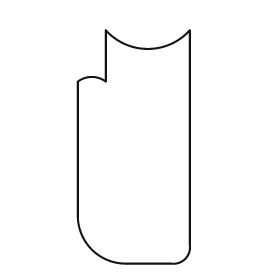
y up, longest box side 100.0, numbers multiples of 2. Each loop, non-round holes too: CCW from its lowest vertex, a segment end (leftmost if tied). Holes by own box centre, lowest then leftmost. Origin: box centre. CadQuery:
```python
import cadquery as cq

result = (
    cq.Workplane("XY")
    .moveTo(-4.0, -50.0)
    .lineTo(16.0, -50.0)
    .threePointArc((22.0, -48.0), (24.0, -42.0))
    .lineTo(24.0, 50.0)
    .threePointArc((6.0, 42.0), (-12.0, 50.0))
    .lineTo(-12.0, 28.0)
    .threePointArc((-18.0, 30.0), (-24.0, 28.0))
    .lineTo(-24.0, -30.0)
    .threePointArc((-18.0, -44.0), (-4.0, -50.0))
    .close()
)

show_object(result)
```